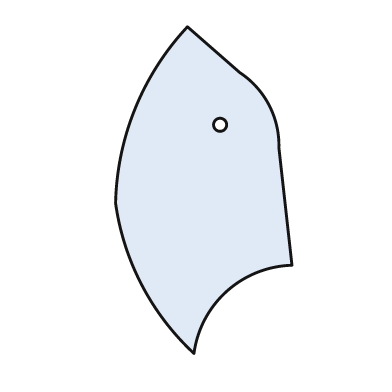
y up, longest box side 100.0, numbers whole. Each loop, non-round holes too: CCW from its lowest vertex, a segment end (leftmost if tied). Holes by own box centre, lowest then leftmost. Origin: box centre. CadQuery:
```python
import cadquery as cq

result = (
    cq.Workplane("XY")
    .moveTo(-3.0, -50.0)
    .threePointArc((7.0, -31.0), (27.0, -23.0))
    .lineTo(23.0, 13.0)
    .threePointArc((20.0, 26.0), (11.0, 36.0))
    .lineTo(-5.0, 50.0)
    .threePointArc((-21.0, 25.0), (-27.0, -4.0))
    .threePointArc((-19.0, -29.0), (-3.0, -50.0))
    .close()
    .moveTo(5.0, 20.0)
    .circle(2.0)
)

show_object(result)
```